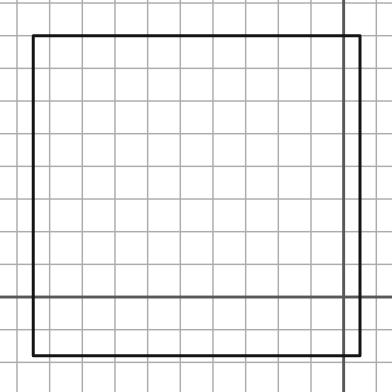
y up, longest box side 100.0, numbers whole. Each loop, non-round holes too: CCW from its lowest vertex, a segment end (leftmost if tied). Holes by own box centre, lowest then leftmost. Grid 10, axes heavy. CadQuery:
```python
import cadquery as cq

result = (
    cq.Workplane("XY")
    .moveTo(-95.0, -18.0)
    .lineTo(5.0, -18.0)
    .lineTo(5.0, 80.0)
    .lineTo(-95.0, 80.0)
    .close()
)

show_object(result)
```